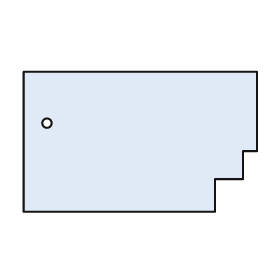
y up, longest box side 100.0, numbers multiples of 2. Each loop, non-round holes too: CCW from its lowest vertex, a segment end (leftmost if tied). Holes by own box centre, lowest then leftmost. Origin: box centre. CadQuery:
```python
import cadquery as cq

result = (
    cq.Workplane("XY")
    .moveTo(-50.0, -30.0)
    .lineTo(32.0, -30.0)
    .lineTo(32.0, -16.0)
    .lineTo(44.0, -16.0)
    .lineTo(44.0, -4.0)
    .lineTo(50.0, -4.0)
    .lineTo(50.0, 30.0)
    .lineTo(-50.0, 30.0)
    .close()
    .moveTo(-40.0, 8.0)
    .circle(2.0)
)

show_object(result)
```